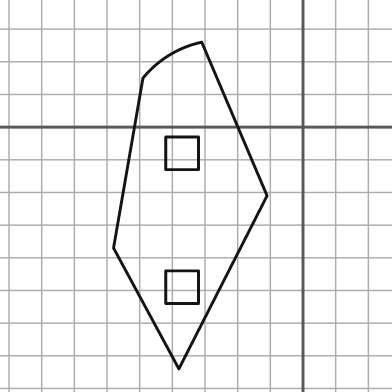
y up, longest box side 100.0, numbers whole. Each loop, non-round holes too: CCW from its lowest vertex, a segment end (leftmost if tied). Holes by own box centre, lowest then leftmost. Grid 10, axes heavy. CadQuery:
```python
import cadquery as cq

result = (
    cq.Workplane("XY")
    .moveTo(-38.0, -74.0)
    .lineTo(-11.0, -21.0)
    .lineTo(-31.0, 26.0)
    .threePointArc((-41.0, 22.0), (-49.0, 15.0))
    .lineTo(-58.0, -37.0)
    .close()
    .moveTo(-42.0, -54.0)
    .lineTo(-32.0, -54.0)
    .lineTo(-32.0, -44.0)
    .lineTo(-42.0, -44.0)
    .close()
    .moveTo(-42.0, -13.0)
    .lineTo(-32.0, -13.0)
    .lineTo(-32.0, -3.0)
    .lineTo(-42.0, -3.0)
    .close()
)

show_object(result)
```